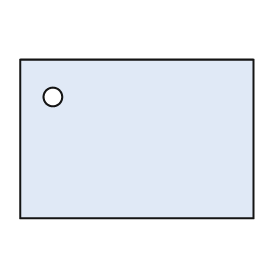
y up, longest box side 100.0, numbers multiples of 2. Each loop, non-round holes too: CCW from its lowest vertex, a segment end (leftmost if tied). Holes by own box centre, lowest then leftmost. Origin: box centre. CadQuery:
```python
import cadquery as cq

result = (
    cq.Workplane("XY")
    .moveTo(-50.0, -34.0)
    .lineTo(50.0, -34.0)
    .lineTo(50.0, 34.0)
    .lineTo(-50.0, 34.0)
    .close()
    .moveTo(-36.0, 18.0)
    .circle(4.0)
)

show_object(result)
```